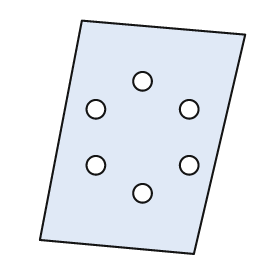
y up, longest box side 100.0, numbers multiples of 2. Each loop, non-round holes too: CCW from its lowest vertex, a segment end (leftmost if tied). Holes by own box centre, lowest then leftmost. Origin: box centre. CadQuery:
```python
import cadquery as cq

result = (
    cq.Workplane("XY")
    .moveTo(22.0, -50.0)
    .lineTo(44.0, 44.0)
    .lineTo(-26.0, 50.0)
    .lineTo(-44.0, -44.0)
    .close()
    .moveTo(0.0, -24.0)
    .circle(4.0)
    .moveTo(-20.0, -12.0)
    .circle(4.0)
    .moveTo(20.0, -12.0)
    .circle(4.0)
    .moveTo(-20.0, 12.0)
    .circle(4.0)
    .moveTo(20.0, 12.0)
    .circle(4.0)
    .moveTo(0.0, 24.0)
    .circle(4.0)
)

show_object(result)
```